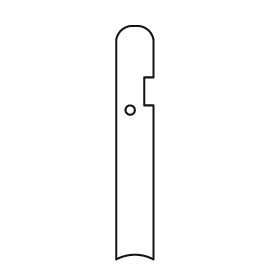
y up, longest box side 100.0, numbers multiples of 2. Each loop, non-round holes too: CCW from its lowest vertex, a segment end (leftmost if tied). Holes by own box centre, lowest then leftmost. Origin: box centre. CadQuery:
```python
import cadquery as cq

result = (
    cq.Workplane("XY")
    .moveTo(-8.0, -50.0)
    .threePointArc((0.0, -48.0), (8.0, -50.0))
    .lineTo(8.0, 16.0)
    .lineTo(4.0, 16.0)
    .lineTo(4.0, 28.0)
    .lineTo(8.0, 28.0)
    .lineTo(8.0, 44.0)
    .threePointArc((6.0, 48.0), (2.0, 50.0))
    .lineTo(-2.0, 50.0)
    .threePointArc((-6.0, 48.0), (-8.0, 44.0))
    .close()
    .moveTo(-2.0, 14.0)
    .circle(2.0)
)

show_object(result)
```